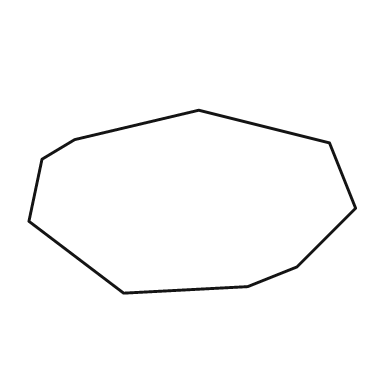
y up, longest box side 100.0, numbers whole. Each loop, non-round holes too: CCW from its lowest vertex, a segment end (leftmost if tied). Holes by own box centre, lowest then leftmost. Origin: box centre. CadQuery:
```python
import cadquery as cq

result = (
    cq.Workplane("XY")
    .moveTo(-21.0, -28.0)
    .lineTo(17.0, -26.0)
    .lineTo(32.0, -20.0)
    .lineTo(50.0, -2.0)
    .lineTo(42.0, 18.0)
    .lineTo(2.0, 28.0)
    .lineTo(-36.0, 19.0)
    .lineTo(-46.0, 13.0)
    .lineTo(-50.0, -6.0)
    .close()
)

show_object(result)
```